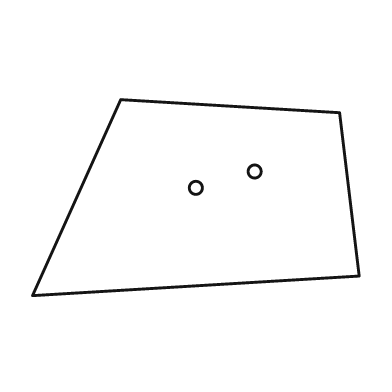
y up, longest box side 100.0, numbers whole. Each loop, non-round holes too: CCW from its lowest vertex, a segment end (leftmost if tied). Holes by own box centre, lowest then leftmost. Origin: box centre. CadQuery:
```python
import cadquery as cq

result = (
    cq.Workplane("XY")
    .moveTo(-50.0, -30.0)
    .lineTo(50.0, -24.0)
    .lineTo(44.0, 26.0)
    .lineTo(-23.0, 30.0)
    .close()
    .moveTo(0.0, 3.0)
    .circle(2.0)
    .moveTo(18.0, 8.0)
    .circle(2.0)
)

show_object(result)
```